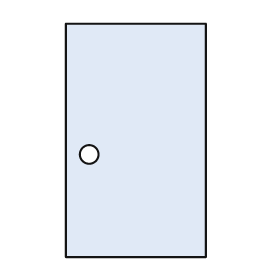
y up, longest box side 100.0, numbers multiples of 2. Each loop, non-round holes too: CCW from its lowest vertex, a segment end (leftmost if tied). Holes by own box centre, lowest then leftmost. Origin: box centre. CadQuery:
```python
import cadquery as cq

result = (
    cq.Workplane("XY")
    .moveTo(-30.0, -50.0)
    .lineTo(30.0, -50.0)
    .lineTo(30.0, 50.0)
    .lineTo(-30.0, 50.0)
    .close()
    .moveTo(-20.0, -6.0)
    .circle(4.0)
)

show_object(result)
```